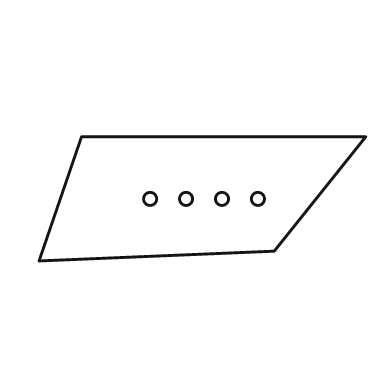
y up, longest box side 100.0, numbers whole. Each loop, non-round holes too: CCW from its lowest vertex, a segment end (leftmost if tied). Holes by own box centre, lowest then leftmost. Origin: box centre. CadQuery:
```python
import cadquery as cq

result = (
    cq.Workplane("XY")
    .moveTo(-50.0, -19.0)
    .lineTo(22.0, -16.0)
    .lineTo(50.0, 19.0)
    .lineTo(-37.0, 19.0)
    .close()
    .moveTo(-16.0, 0.0)
    .circle(2.0)
    .moveTo(-5.0, 0.0)
    .circle(2.0)
    .moveTo(6.0, 0.0)
    .circle(2.0)
    .moveTo(17.0, 0.0)
    .circle(2.0)
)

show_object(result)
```